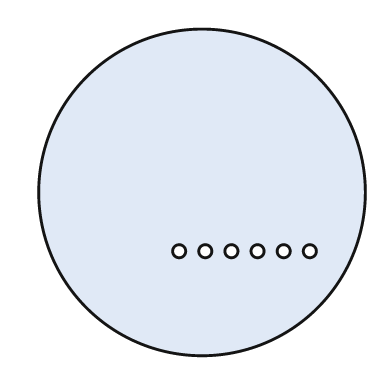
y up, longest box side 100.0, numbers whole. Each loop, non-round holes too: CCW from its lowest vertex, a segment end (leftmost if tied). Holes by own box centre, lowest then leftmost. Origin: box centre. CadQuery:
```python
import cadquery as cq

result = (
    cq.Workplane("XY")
    .moveTo(0.0, 0.0)
    .circle(50.0)
    .moveTo(-7.0, -18.0)
    .circle(2.0)
    .moveTo(1.0, -18.0)
    .circle(2.0)
    .moveTo(9.0, -18.0)
    .circle(2.0)
    .moveTo(17.0, -18.0)
    .circle(2.0)
    .moveTo(25.0, -18.0)
    .circle(2.0)
    .moveTo(33.0, -18.0)
    .circle(2.0)
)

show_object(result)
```